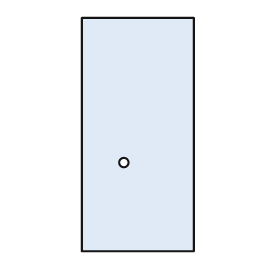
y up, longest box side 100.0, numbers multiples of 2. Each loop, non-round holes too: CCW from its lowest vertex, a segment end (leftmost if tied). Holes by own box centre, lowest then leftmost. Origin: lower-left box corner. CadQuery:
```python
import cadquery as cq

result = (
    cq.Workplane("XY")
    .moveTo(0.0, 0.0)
    .lineTo(48.0, 0.0)
    .lineTo(48.0, 100.0)
    .lineTo(0.0, 100.0)
    .close()
    .moveTo(18.0, 38.0)
    .circle(2.0)
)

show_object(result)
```